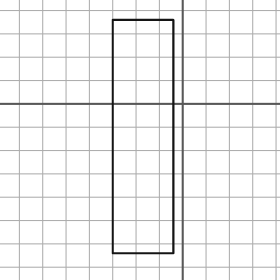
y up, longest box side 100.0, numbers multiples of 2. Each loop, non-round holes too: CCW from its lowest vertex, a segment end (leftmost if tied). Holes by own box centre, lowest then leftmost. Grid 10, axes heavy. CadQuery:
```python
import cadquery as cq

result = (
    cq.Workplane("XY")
    .moveTo(-30.0, -64.0)
    .lineTo(-4.0, -64.0)
    .lineTo(-4.0, 36.0)
    .lineTo(-30.0, 36.0)
    .close()
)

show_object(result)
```